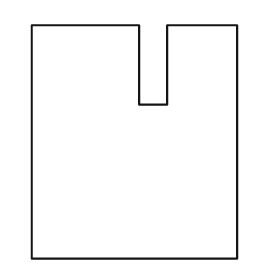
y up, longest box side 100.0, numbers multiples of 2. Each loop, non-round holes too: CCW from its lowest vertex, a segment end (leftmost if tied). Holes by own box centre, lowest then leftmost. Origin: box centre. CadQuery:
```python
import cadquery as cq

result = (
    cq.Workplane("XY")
    .moveTo(-44.0, -50.0)
    .lineTo(44.0, -50.0)
    .lineTo(44.0, 50.0)
    .lineTo(14.0, 50.0)
    .lineTo(14.0, 16.0)
    .lineTo(2.0, 16.0)
    .lineTo(2.0, 50.0)
    .lineTo(-44.0, 50.0)
    .close()
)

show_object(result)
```